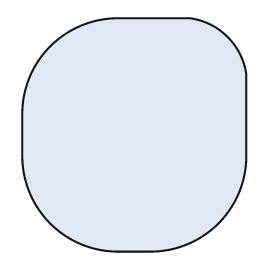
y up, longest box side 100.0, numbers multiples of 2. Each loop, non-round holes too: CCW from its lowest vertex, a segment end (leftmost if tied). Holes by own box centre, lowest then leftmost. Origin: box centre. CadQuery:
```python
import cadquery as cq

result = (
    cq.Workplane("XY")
    .moveTo(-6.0, -50.0)
    .lineTo(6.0, -50.0)
    .threePointArc((36.0, -38.0), (48.0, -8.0))
    .lineTo(48.0, 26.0)
    .threePointArc((40.0, 42.0), (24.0, 50.0))
    .lineTo(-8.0, 50.0)
    .threePointArc((-36.0, 38.0), (-48.0, 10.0))
    .lineTo(-48.0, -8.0)
    .threePointArc((-36.0, -38.0), (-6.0, -50.0))
    .close()
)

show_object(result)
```